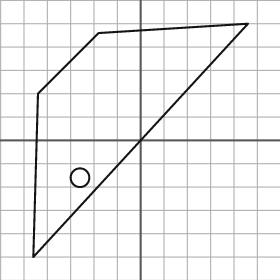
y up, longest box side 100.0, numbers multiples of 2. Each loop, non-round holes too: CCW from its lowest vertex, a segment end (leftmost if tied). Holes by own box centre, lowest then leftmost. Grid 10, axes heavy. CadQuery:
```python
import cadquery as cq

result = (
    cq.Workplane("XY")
    .moveTo(-46.0, -50.0)
    .lineTo(46.0, 50.0)
    .lineTo(-18.0, 46.0)
    .lineTo(-44.0, 20.0)
    .close()
    .moveTo(-26.0, -16.0)
    .circle(4.0)
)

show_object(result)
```